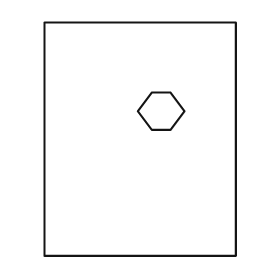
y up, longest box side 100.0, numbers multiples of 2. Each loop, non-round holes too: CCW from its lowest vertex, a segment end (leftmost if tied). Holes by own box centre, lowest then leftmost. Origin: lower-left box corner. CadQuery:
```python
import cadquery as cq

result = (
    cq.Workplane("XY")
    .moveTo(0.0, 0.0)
    .lineTo(82.0, 0.0)
    .lineTo(82.0, 100.0)
    .lineTo(0.0, 100.0)
    .close()
    .moveTo(46.0, 54.0)
    .lineTo(54.0, 54.0)
    .lineTo(60.0, 62.0)
    .lineTo(54.0, 70.0)
    .lineTo(46.0, 70.0)
    .lineTo(40.0, 62.0)
    .close()
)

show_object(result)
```